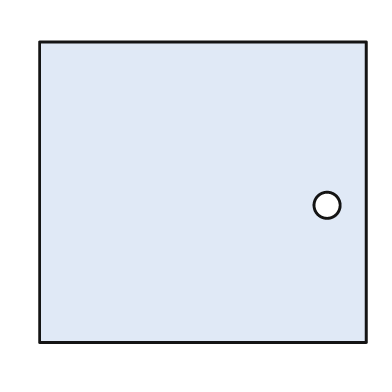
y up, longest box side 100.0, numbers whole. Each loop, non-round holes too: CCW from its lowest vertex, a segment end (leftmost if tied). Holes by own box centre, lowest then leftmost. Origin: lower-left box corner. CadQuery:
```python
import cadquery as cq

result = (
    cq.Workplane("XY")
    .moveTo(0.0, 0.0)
    .lineTo(100.0, 0.0)
    .lineTo(100.0, 92.0)
    .lineTo(0.0, 92.0)
    .close()
    .moveTo(88.0, 42.0)
    .circle(4.0)
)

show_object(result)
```